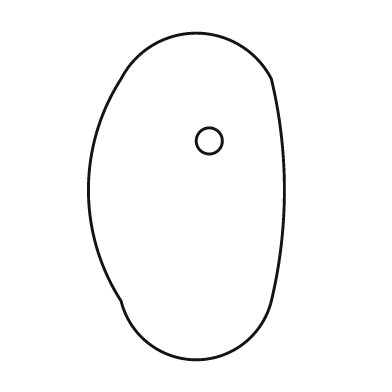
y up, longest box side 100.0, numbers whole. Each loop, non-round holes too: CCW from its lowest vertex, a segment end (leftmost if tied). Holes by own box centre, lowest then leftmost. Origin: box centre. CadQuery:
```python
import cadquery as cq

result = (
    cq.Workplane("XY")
    .moveTo(-20.0, -32.0)
    .threePointArc((3.0, -50.0), (26.0, -32.0))
    .threePointArc((30.0, 2.0), (26.0, 36.0))
    .threePointArc((3.0, 50.0), (-20.0, 36.0))
    .threePointArc((-30.0, 2.0), (-20.0, -32.0))
    .close()
    .moveTo(7.0, 17.0)
    .circle(4.0)
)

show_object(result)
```